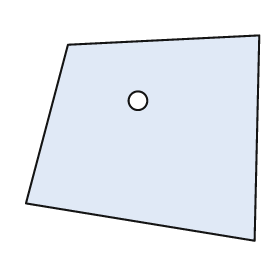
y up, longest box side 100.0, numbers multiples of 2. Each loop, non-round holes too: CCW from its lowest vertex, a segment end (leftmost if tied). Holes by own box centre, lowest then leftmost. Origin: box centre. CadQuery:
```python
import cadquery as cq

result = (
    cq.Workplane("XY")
    .moveTo(48.0, -44.0)
    .lineTo(50.0, 44.0)
    .lineTo(-32.0, 40.0)
    .lineTo(-50.0, -28.0)
    .close()
    .moveTo(-2.0, 16.0)
    .circle(4.0)
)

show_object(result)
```